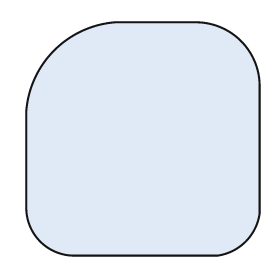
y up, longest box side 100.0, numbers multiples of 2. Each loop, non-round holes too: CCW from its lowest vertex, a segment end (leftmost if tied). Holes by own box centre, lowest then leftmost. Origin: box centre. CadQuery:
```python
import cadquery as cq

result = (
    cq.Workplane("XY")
    .moveTo(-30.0, -50.0)
    .lineTo(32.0, -50.0)
    .threePointArc((44.0, -44.0), (50.0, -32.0))
    .lineTo(50.0, 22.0)
    .threePointArc((42.0, 42.0), (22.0, 50.0))
    .lineTo(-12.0, 50.0)
    .threePointArc((-38.0, 38.0), (-50.0, 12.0))
    .lineTo(-50.0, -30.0)
    .threePointArc((-44.0, -44.0), (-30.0, -50.0))
    .close()
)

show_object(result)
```